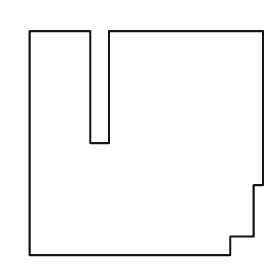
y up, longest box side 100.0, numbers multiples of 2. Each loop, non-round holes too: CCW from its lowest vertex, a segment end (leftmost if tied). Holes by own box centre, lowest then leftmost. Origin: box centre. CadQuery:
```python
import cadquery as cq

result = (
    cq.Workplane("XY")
    .moveTo(-50.0, -48.0)
    .lineTo(36.0, -48.0)
    .lineTo(36.0, -40.0)
    .lineTo(46.0, -40.0)
    .lineTo(46.0, -18.0)
    .lineTo(50.0, -18.0)
    .lineTo(50.0, 48.0)
    .lineTo(-16.0, 48.0)
    .lineTo(-16.0, 0.0)
    .lineTo(-24.0, 0.0)
    .lineTo(-24.0, 48.0)
    .lineTo(-50.0, 48.0)
    .close()
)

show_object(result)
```